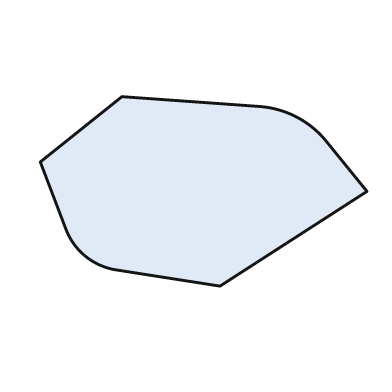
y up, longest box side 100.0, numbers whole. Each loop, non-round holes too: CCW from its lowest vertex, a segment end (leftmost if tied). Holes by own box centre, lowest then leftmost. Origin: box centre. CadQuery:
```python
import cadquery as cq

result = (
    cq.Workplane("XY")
    .moveTo(5.0, -29.0)
    .lineTo(50.0, 0.0)
    .lineTo(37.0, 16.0)
    .threePointArc((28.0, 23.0), (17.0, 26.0))
    .lineTo(-25.0, 29.0)
    .lineTo(-50.0, 9.0)
    .lineTo(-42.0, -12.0)
    .threePointArc((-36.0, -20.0), (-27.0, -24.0))
    .close()
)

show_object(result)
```